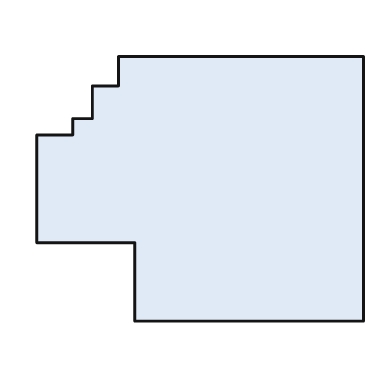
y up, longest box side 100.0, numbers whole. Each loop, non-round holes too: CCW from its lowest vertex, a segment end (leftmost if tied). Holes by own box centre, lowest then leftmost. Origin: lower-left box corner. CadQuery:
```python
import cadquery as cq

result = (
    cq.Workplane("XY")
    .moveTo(30.0, 0.0)
    .lineTo(100.0, 0.0)
    .lineTo(100.0, 81.0)
    .lineTo(25.0, 81.0)
    .lineTo(25.0, 72.0)
    .lineTo(17.0, 72.0)
    .lineTo(17.0, 62.0)
    .lineTo(11.0, 62.0)
    .lineTo(11.0, 57.0)
    .lineTo(0.0, 57.0)
    .lineTo(0.0, 24.0)
    .lineTo(30.0, 24.0)
    .close()
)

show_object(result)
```